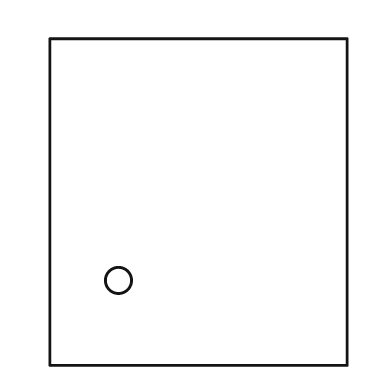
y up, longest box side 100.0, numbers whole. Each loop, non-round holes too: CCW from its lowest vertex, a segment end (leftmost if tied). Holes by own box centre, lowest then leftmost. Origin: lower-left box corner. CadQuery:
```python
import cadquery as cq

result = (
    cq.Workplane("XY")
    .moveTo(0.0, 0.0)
    .lineTo(91.0, 0.0)
    .lineTo(91.0, 100.0)
    .lineTo(0.0, 100.0)
    .close()
    .moveTo(21.0, 26.0)
    .circle(4.0)
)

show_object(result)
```